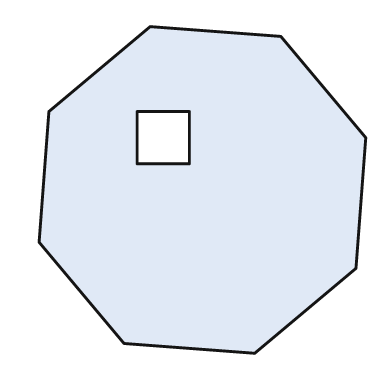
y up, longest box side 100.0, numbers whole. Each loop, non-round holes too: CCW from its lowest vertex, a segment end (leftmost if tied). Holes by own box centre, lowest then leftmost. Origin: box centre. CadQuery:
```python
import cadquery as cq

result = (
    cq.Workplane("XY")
    .moveTo(16.0, -50.0)
    .lineTo(47.0, -24.0)
    .lineTo(50.0, 16.0)
    .lineTo(24.0, 47.0)
    .lineTo(-16.0, 50.0)
    .lineTo(-47.0, 24.0)
    .lineTo(-50.0, -16.0)
    .lineTo(-24.0, -47.0)
    .close()
    .moveTo(-20.0, 8.0)
    .lineTo(-4.0, 8.0)
    .lineTo(-4.0, 24.0)
    .lineTo(-20.0, 24.0)
    .close()
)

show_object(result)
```